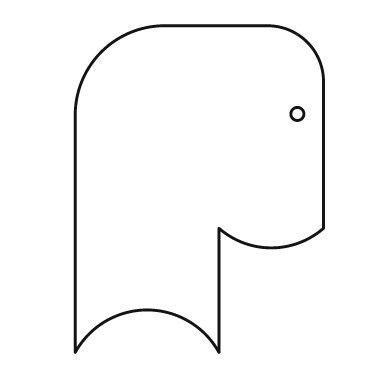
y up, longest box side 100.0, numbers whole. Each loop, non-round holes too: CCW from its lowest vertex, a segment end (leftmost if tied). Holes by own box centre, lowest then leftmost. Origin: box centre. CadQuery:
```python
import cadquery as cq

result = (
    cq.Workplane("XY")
    .moveTo(-38.0, -50.0)
    .threePointArc((-16.0, -37.0), (6.0, -50.0))
    .lineTo(6.0, -12.0)
    .threePointArc((22.0, -18.0), (38.0, -12.0))
    .lineTo(38.0, 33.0)
    .threePointArc((33.0, 45.0), (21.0, 50.0))
    .lineTo(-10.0, 50.0)
    .threePointArc((-30.0, 42.0), (-38.0, 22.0))
    .close()
    .moveTo(30.0, 23.0)
    .circle(2.0)
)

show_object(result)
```